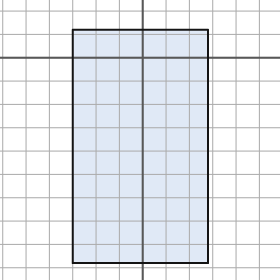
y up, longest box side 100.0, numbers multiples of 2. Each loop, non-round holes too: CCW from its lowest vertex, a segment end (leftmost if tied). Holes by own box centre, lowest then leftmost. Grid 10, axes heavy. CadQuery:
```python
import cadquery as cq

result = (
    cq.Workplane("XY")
    .moveTo(-30.0, -88.0)
    .lineTo(28.0, -88.0)
    .lineTo(28.0, 12.0)
    .lineTo(-30.0, 12.0)
    .close()
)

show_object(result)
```